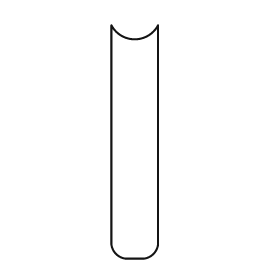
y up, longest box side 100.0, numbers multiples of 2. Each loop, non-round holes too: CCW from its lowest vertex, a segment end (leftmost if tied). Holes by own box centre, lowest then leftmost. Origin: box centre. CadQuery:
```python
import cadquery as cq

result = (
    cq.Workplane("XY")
    .moveTo(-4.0, -50.0)
    .lineTo(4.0, -50.0)
    .threePointArc((8.0, -48.0), (10.0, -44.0))
    .lineTo(10.0, 50.0)
    .threePointArc((0.0, 44.0), (-10.0, 50.0))
    .lineTo(-10.0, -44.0)
    .threePointArc((-8.0, -48.0), (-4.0, -50.0))
    .close()
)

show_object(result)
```